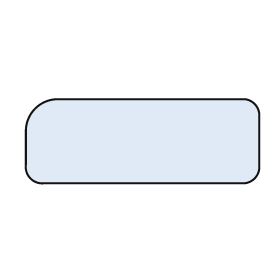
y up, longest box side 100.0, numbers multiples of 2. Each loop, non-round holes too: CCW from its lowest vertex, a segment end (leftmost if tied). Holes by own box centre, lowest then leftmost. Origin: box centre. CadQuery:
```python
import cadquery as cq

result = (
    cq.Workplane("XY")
    .moveTo(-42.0, -18.0)
    .lineTo(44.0, -18.0)
    .threePointArc((48.0, -16.0), (50.0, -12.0))
    .lineTo(50.0, 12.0)
    .threePointArc((48.0, 16.0), (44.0, 18.0))
    .lineTo(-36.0, 18.0)
    .threePointArc((-46.0, 14.0), (-50.0, 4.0))
    .lineTo(-50.0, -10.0)
    .threePointArc((-48.0, -16.0), (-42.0, -18.0))
    .close()
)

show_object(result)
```